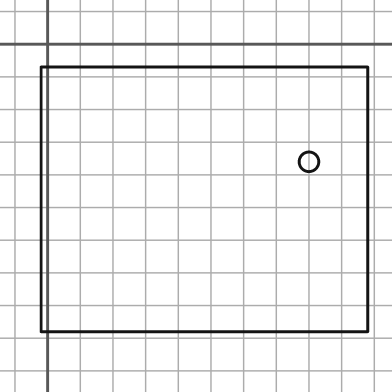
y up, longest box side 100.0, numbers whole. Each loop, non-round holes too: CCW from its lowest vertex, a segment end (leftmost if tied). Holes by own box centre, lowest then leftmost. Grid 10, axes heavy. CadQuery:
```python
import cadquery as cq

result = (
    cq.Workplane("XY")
    .moveTo(-2.0, -88.0)
    .lineTo(98.0, -88.0)
    .lineTo(98.0, -7.0)
    .lineTo(-2.0, -7.0)
    .close()
    .moveTo(80.0, -36.0)
    .circle(3.0)
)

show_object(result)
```